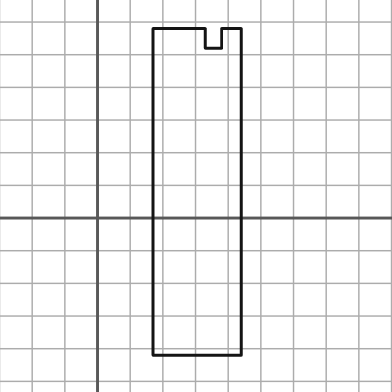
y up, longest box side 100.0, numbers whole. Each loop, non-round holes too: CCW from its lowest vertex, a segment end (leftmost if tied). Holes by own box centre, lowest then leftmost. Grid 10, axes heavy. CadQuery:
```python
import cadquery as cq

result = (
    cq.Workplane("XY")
    .moveTo(17.0, -42.0)
    .lineTo(44.0, -42.0)
    .lineTo(44.0, 58.0)
    .lineTo(38.0, 58.0)
    .lineTo(38.0, 52.0)
    .lineTo(33.0, 52.0)
    .lineTo(33.0, 58.0)
    .lineTo(17.0, 58.0)
    .close()
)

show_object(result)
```